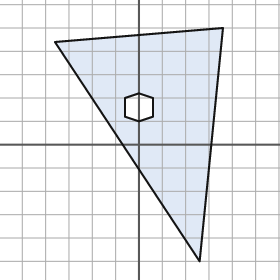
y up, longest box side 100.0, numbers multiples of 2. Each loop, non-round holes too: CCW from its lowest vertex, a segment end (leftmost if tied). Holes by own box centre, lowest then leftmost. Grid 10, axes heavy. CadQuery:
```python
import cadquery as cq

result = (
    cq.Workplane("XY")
    .moveTo(26.0, -50.0)
    .lineTo(36.0, 50.0)
    .lineTo(-36.0, 44.0)
    .close()
    .moveTo(0.0, 10.0)
    .lineTo(6.0, 12.0)
    .lineTo(6.0, 20.0)
    .lineTo(0.0, 22.0)
    .lineTo(-6.0, 20.0)
    .lineTo(-6.0, 12.0)
    .close()
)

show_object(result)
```